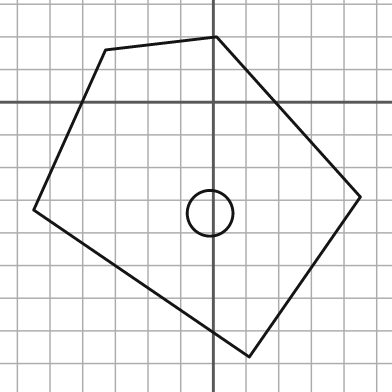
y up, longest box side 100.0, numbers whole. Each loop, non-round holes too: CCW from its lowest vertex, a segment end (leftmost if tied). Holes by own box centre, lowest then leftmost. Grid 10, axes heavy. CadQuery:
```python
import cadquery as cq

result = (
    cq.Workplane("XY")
    .moveTo(11.0, -78.0)
    .lineTo(45.0, -29.0)
    .lineTo(1.0, 20.0)
    .lineTo(-33.0, 16.0)
    .lineTo(-55.0, -33.0)
    .close()
    .moveTo(-1.0, -34.0)
    .circle(7.0)
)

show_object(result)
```